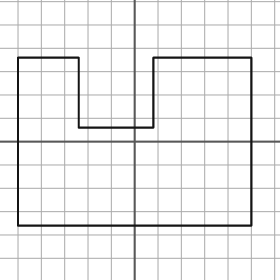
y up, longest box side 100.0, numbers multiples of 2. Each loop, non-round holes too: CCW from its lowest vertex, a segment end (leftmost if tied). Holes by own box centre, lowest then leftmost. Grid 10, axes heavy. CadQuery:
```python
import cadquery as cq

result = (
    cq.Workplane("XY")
    .moveTo(-50.0, -36.0)
    .lineTo(50.0, -36.0)
    .lineTo(50.0, 36.0)
    .lineTo(8.0, 36.0)
    .lineTo(8.0, 6.0)
    .lineTo(-24.0, 6.0)
    .lineTo(-24.0, 36.0)
    .lineTo(-50.0, 36.0)
    .close()
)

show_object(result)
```